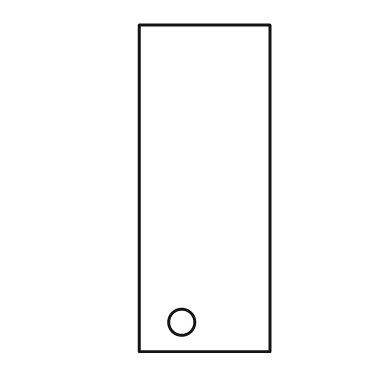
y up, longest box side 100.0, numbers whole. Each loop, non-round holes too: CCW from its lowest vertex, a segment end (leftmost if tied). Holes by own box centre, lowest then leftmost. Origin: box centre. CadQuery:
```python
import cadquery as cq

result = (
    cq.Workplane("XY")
    .moveTo(-20.0, -50.0)
    .lineTo(20.0, -50.0)
    .lineTo(20.0, 50.0)
    .lineTo(-20.0, 50.0)
    .close()
    .moveTo(-7.0, -41.0)
    .circle(4.0)
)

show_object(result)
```